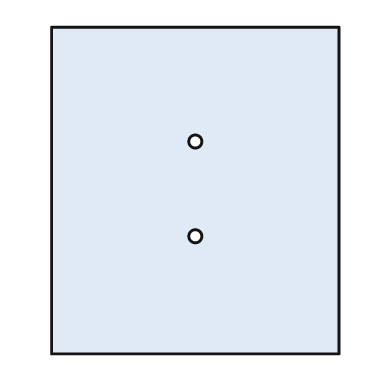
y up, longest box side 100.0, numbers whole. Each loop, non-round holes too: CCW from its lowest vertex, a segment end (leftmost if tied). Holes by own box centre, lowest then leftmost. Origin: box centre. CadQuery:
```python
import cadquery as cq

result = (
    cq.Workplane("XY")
    .moveTo(-44.0, -50.0)
    .lineTo(44.0, -50.0)
    .lineTo(44.0, 50.0)
    .lineTo(-44.0, 50.0)
    .close()
    .moveTo(0.0, -14.0)
    .circle(2.0)
    .moveTo(0.0, 15.0)
    .circle(2.0)
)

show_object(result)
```